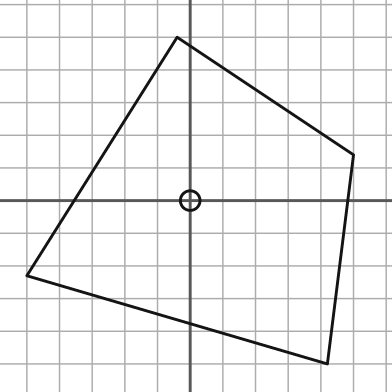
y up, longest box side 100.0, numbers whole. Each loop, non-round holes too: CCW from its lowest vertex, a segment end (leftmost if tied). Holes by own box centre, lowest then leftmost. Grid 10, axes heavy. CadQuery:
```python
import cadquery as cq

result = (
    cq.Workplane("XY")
    .moveTo(42.0, -50.0)
    .lineTo(50.0, 14.0)
    .lineTo(-4.0, 50.0)
    .lineTo(-50.0, -23.0)
    .close()
    .moveTo(0.0, 0.0)
    .circle(3.0)
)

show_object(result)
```